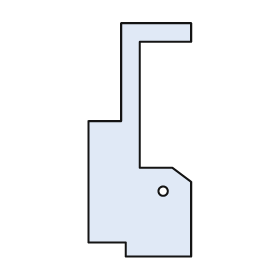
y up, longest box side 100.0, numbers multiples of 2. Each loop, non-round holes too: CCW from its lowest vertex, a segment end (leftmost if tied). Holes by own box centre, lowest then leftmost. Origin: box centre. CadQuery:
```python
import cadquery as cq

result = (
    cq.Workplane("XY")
    .moveTo(-6.0, -50.0)
    .lineTo(22.0, -50.0)
    .lineTo(22.0, -18.0)
    .lineTo(14.0, -12.0)
    .lineTo(0.0, -12.0)
    .lineTo(0.0, 42.0)
    .lineTo(22.0, 42.0)
    .lineTo(22.0, 50.0)
    .lineTo(-8.0, 50.0)
    .lineTo(-8.0, 8.0)
    .lineTo(-22.0, 8.0)
    .lineTo(-22.0, -44.0)
    .lineTo(-6.0, -44.0)
    .close()
    .moveTo(10.0, -22.0)
    .circle(2.0)
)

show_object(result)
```